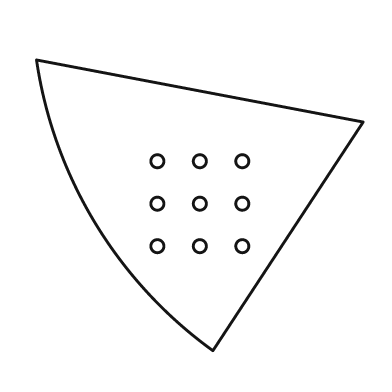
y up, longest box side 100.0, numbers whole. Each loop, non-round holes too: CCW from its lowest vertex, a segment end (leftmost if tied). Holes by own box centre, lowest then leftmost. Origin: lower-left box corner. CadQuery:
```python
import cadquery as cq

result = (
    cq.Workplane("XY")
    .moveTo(54.0, 0.0)
    .lineTo(100.0, 70.0)
    .lineTo(0.0, 89.0)
    .threePointArc((18.0, 39.0), (54.0, 0.0))
    .close()
    .moveTo(37.0, 32.0)
    .circle(2.0)
    .moveTo(50.0, 32.0)
    .circle(2.0)
    .moveTo(63.0, 32.0)
    .circle(2.0)
    .moveTo(37.0, 45.0)
    .circle(2.0)
    .moveTo(50.0, 45.0)
    .circle(2.0)
    .moveTo(63.0, 45.0)
    .circle(2.0)
    .moveTo(37.0, 58.0)
    .circle(2.0)
    .moveTo(50.0, 58.0)
    .circle(2.0)
    .moveTo(63.0, 58.0)
    .circle(2.0)
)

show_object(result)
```